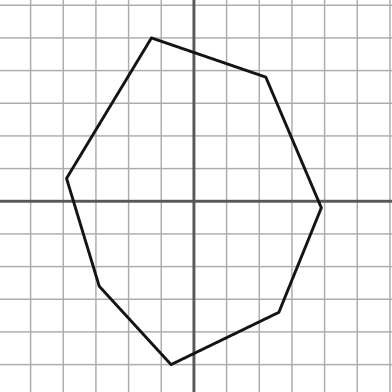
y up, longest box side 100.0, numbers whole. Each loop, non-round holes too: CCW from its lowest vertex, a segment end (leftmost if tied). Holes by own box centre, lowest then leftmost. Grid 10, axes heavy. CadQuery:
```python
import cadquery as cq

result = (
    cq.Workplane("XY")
    .moveTo(-7.0, -50.0)
    .lineTo(26.0, -34.0)
    .lineTo(39.0, -2.0)
    .lineTo(22.0, 38.0)
    .lineTo(-13.0, 50.0)
    .lineTo(-39.0, 7.0)
    .lineTo(-29.0, -26.0)
    .close()
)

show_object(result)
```